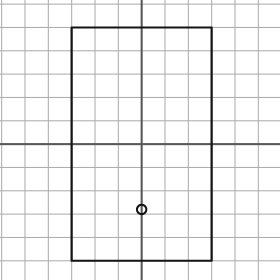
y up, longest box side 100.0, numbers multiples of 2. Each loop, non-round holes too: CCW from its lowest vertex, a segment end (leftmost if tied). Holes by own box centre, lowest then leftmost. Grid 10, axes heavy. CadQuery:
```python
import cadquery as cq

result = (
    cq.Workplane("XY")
    .moveTo(-30.0, -50.0)
    .lineTo(30.0, -50.0)
    .lineTo(30.0, 50.0)
    .lineTo(-30.0, 50.0)
    .close()
    .moveTo(0.0, -28.0)
    .circle(2.0)
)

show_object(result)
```